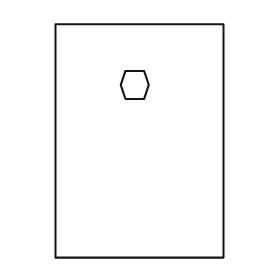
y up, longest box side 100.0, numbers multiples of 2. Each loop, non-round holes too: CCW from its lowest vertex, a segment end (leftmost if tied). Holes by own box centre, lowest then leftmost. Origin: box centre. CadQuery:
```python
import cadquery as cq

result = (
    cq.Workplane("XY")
    .moveTo(-36.0, -50.0)
    .lineTo(36.0, -50.0)
    .lineTo(36.0, 50.0)
    .lineTo(-36.0, 50.0)
    .close()
    .moveTo(-6.0, 18.0)
    .lineTo(2.0, 18.0)
    .lineTo(4.0, 24.0)
    .lineTo(2.0, 30.0)
    .lineTo(-6.0, 30.0)
    .lineTo(-8.0, 24.0)
    .close()
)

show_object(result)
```